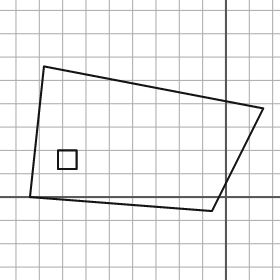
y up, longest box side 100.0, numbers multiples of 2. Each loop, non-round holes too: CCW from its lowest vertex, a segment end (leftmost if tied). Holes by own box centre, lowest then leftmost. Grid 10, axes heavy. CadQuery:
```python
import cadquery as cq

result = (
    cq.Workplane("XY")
    .moveTo(-6.0, -6.0)
    .lineTo(16.0, 38.0)
    .lineTo(-78.0, 56.0)
    .lineTo(-84.0, 0.0)
    .close()
    .moveTo(-72.0, 12.0)
    .lineTo(-64.0, 12.0)
    .lineTo(-64.0, 20.0)
    .lineTo(-72.0, 20.0)
    .close()
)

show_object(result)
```